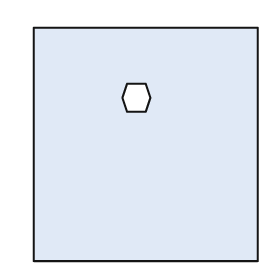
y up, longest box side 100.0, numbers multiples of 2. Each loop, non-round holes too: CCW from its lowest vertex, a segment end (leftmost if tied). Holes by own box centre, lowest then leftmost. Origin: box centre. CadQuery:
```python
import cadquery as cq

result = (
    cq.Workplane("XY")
    .moveTo(-48.0, -50.0)
    .lineTo(48.0, -50.0)
    .lineTo(48.0, 50.0)
    .lineTo(-48.0, 50.0)
    .close()
    .moveTo(-8.0, 14.0)
    .lineTo(0.0, 14.0)
    .lineTo(2.0, 20.0)
    .lineTo(0.0, 26.0)
    .lineTo(-8.0, 26.0)
    .lineTo(-10.0, 20.0)
    .close()
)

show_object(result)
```